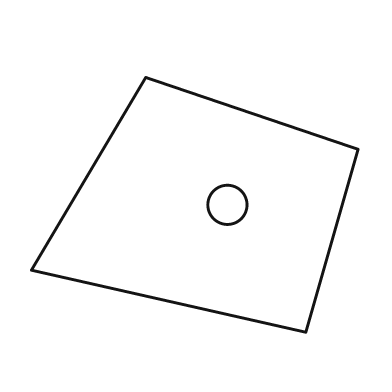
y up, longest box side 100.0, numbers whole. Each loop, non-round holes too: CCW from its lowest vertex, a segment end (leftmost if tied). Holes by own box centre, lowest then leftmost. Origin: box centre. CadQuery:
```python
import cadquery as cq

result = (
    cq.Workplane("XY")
    .moveTo(34.0, -39.0)
    .lineTo(50.0, 17.0)
    .lineTo(-15.0, 39.0)
    .lineTo(-50.0, -20.0)
    .close()
    .moveTo(10.0, 0.0)
    .circle(6.0)
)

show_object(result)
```